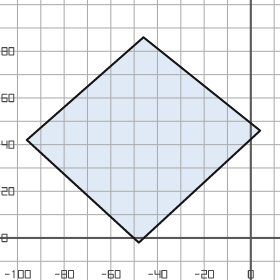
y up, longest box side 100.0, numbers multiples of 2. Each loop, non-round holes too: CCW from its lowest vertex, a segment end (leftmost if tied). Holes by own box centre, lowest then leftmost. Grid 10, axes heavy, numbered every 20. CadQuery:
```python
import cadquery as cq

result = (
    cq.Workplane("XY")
    .moveTo(-48.0, -2.0)
    .lineTo(4.0, 46.0)
    .lineTo(-46.0, 86.0)
    .lineTo(-96.0, 42.0)
    .close()
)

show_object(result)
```